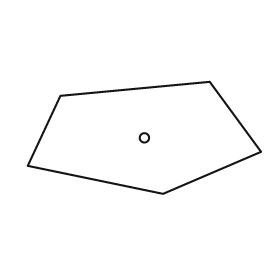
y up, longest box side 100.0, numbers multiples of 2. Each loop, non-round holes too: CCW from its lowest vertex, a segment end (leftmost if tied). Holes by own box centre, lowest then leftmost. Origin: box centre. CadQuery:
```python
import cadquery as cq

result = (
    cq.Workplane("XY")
    .moveTo(8.0, -24.0)
    .lineTo(50.0, -6.0)
    .lineTo(28.0, 24.0)
    .lineTo(-36.0, 18.0)
    .lineTo(-50.0, -12.0)
    .close()
    .moveTo(0.0, 0.0)
    .circle(2.0)
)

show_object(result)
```